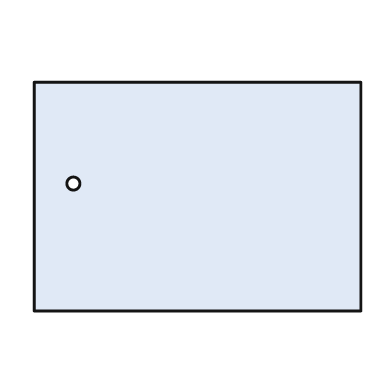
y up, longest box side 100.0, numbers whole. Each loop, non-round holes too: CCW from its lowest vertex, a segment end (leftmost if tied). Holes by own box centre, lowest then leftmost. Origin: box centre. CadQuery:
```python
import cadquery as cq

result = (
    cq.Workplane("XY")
    .moveTo(-50.0, -35.0)
    .lineTo(50.0, -35.0)
    .lineTo(50.0, 35.0)
    .lineTo(-50.0, 35.0)
    .close()
    .moveTo(-38.0, 4.0)
    .circle(2.0)
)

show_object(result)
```